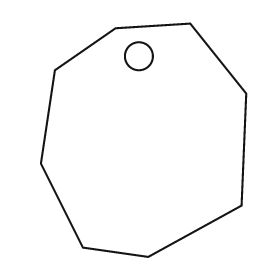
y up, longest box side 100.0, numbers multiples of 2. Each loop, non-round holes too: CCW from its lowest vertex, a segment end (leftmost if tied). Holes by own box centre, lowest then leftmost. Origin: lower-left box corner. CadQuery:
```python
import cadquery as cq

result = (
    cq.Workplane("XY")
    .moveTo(46.0, 0.0)
    .lineTo(86.0, 22.0)
    .lineTo(88.0, 70.0)
    .lineTo(64.0, 100.0)
    .lineTo(32.0, 98.0)
    .lineTo(6.0, 80.0)
    .lineTo(0.0, 40.0)
    .lineTo(18.0, 4.0)
    .close()
    .moveTo(42.0, 86.0)
    .circle(6.0)
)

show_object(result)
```